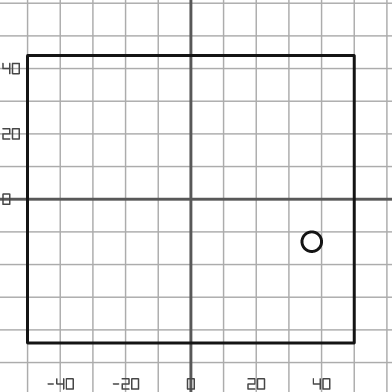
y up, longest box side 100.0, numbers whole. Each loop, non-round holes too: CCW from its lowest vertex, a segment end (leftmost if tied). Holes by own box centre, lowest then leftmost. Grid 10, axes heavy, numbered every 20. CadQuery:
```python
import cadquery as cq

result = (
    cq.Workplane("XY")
    .moveTo(-50.0, -44.0)
    .lineTo(50.0, -44.0)
    .lineTo(50.0, 44.0)
    .lineTo(-50.0, 44.0)
    .close()
    .moveTo(37.0, -13.0)
    .circle(3.0)
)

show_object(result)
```